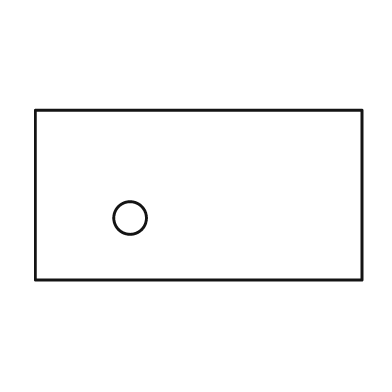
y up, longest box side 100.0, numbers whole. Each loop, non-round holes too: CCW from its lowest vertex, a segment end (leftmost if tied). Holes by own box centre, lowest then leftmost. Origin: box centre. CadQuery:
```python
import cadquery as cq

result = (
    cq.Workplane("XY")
    .moveTo(-50.0, -26.0)
    .lineTo(50.0, -26.0)
    .lineTo(50.0, 26.0)
    .lineTo(-50.0, 26.0)
    .close()
    .moveTo(-21.0, -7.0)
    .circle(5.0)
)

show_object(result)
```